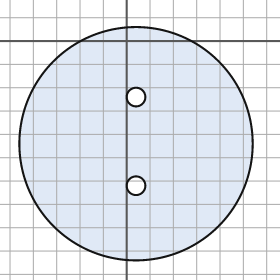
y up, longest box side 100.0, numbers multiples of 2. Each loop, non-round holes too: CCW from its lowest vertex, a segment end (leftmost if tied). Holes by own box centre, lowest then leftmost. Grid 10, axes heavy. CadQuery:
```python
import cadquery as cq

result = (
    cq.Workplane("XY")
    .moveTo(4.0, -44.0)
    .circle(50.0)
    .moveTo(4.0, -62.0)
    .circle(4.0)
    .moveTo(4.0, -24.0)
    .circle(4.0)
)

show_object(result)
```